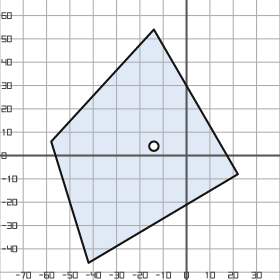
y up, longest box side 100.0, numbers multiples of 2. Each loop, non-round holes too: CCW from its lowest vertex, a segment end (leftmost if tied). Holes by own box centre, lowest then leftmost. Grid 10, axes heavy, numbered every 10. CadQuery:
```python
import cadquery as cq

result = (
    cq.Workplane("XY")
    .moveTo(-42.0, -46.0)
    .lineTo(22.0, -8.0)
    .lineTo(-14.0, 54.0)
    .lineTo(-58.0, 6.0)
    .close()
    .moveTo(-14.0, 4.0)
    .circle(2.0)
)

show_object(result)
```